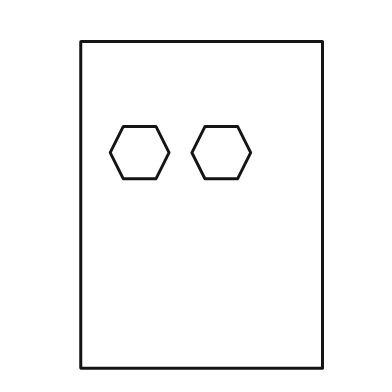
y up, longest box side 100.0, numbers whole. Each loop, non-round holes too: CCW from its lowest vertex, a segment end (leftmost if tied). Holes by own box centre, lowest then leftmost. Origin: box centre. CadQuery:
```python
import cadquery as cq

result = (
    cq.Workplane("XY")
    .moveTo(-37.0, -50.0)
    .lineTo(37.0, -50.0)
    .lineTo(37.0, 50.0)
    .lineTo(-37.0, 50.0)
    .close()
    .moveTo(-24.0, 8.0)
    .lineTo(-14.0, 8.0)
    .lineTo(-10.0, 16.0)
    .lineTo(-14.0, 24.0)
    .lineTo(-24.0, 24.0)
    .lineTo(-28.0, 16.0)
    .close()
    .moveTo(1.0, 8.0)
    .lineTo(11.0, 8.0)
    .lineTo(15.0, 16.0)
    .lineTo(11.0, 24.0)
    .lineTo(1.0, 24.0)
    .lineTo(-3.0, 16.0)
    .close()
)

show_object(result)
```